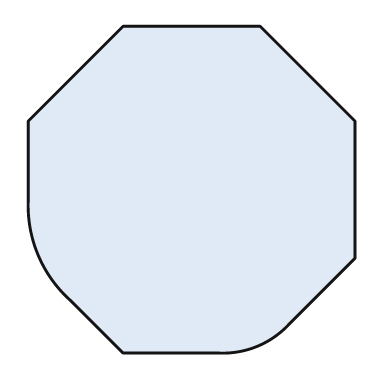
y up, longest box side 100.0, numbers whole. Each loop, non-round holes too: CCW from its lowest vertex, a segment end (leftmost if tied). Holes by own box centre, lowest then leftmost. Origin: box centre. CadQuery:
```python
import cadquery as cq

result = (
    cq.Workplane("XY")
    .moveTo(-21.0, -50.0)
    .lineTo(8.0, -50.0)
    .threePointArc((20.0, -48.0), (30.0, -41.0))
    .lineTo(50.0, -21.0)
    .lineTo(50.0, 21.0)
    .lineTo(21.0, 50.0)
    .lineTo(-21.0, 50.0)
    .lineTo(-50.0, 21.0)
    .lineTo(-50.0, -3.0)
    .threePointArc((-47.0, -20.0), (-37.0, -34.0))
    .close()
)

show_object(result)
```